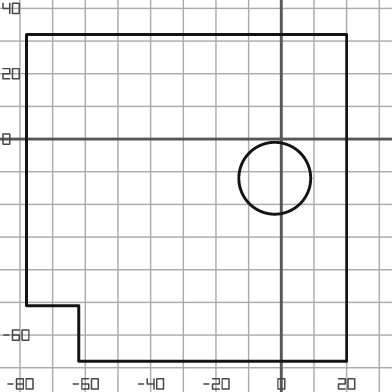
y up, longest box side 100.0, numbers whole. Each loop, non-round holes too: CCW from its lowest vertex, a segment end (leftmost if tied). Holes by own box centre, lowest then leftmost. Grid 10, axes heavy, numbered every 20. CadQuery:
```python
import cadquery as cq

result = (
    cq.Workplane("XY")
    .moveTo(-62.0, -68.0)
    .lineTo(20.0, -68.0)
    .lineTo(20.0, 32.0)
    .lineTo(-78.0, 32.0)
    .lineTo(-78.0, -51.0)
    .lineTo(-62.0, -51.0)
    .close()
    .moveTo(-2.0, -12.0)
    .circle(11.0)
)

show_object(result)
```